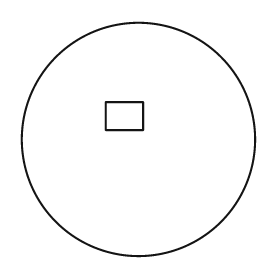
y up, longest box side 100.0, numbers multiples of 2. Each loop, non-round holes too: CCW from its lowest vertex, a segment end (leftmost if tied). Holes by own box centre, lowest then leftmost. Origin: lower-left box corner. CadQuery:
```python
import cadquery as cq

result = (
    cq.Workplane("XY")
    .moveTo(50.0, 50.0)
    .circle(50.0)
    .moveTo(36.0, 54.0)
    .lineTo(52.0, 54.0)
    .lineTo(52.0, 66.0)
    .lineTo(36.0, 66.0)
    .close()
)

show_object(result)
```